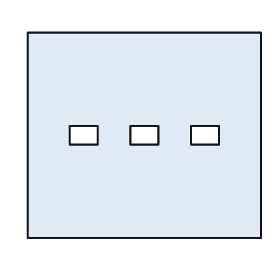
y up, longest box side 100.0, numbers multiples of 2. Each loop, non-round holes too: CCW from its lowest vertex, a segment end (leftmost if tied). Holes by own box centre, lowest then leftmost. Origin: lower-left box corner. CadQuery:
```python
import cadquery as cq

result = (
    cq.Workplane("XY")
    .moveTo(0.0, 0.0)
    .lineTo(100.0, 0.0)
    .lineTo(100.0, 88.0)
    .lineTo(0.0, 88.0)
    .close()
    .moveTo(18.0, 40.0)
    .lineTo(30.0, 40.0)
    .lineTo(30.0, 48.0)
    .lineTo(18.0, 48.0)
    .close()
    .moveTo(44.0, 40.0)
    .lineTo(56.0, 40.0)
    .lineTo(56.0, 48.0)
    .lineTo(44.0, 48.0)
    .close()
    .moveTo(70.0, 40.0)
    .lineTo(82.0, 40.0)
    .lineTo(82.0, 48.0)
    .lineTo(70.0, 48.0)
    .close()
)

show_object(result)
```